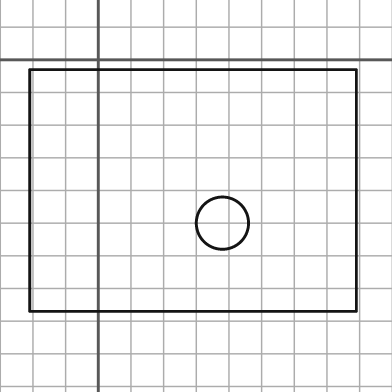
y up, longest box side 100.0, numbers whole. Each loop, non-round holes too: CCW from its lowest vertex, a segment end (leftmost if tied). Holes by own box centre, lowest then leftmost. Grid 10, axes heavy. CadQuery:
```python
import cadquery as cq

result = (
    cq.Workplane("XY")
    .moveTo(-21.0, -77.0)
    .lineTo(79.0, -77.0)
    .lineTo(79.0, -3.0)
    .lineTo(-21.0, -3.0)
    .close()
    .moveTo(38.0, -50.0)
    .circle(8.0)
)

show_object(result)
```